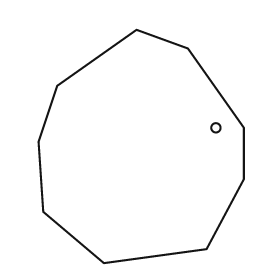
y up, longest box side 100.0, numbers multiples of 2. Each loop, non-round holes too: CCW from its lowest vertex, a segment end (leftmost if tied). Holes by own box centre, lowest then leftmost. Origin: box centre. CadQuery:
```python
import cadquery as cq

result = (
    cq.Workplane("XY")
    .moveTo(-16.0, -50.0)
    .lineTo(28.0, -44.0)
    .lineTo(44.0, -14.0)
    .lineTo(44.0, 8.0)
    .lineTo(20.0, 42.0)
    .lineTo(-2.0, 50.0)
    .lineTo(-36.0, 26.0)
    .lineTo(-44.0, 2.0)
    .lineTo(-42.0, -28.0)
    .close()
    .moveTo(32.0, 8.0)
    .circle(2.0)
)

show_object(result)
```